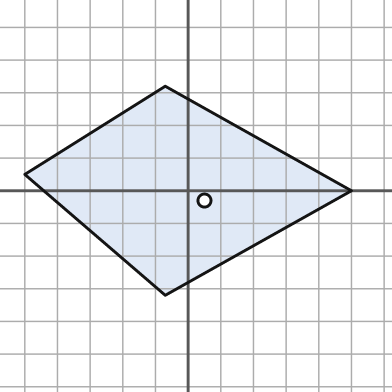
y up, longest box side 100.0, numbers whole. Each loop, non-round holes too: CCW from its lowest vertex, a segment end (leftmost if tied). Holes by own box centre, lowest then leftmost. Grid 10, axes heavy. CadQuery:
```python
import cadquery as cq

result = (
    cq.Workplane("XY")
    .moveTo(-7.0, -32.0)
    .lineTo(50.0, 0.0)
    .lineTo(-7.0, 32.0)
    .lineTo(-50.0, 5.0)
    .close()
    .moveTo(5.0, -3.0)
    .circle(2.0)
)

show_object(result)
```